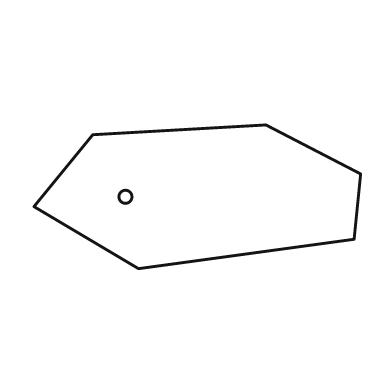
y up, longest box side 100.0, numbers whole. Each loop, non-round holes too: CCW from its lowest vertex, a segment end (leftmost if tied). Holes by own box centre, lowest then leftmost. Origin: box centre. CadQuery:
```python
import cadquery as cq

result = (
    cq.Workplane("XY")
    .moveTo(-18.0, -22.0)
    .lineTo(48.0, -13.0)
    .lineTo(50.0, 7.0)
    .lineTo(21.0, 22.0)
    .lineTo(-32.0, 19.0)
    .lineTo(-50.0, -3.0)
    .close()
    .moveTo(-22.0, 0.0)
    .circle(2.0)
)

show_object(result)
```